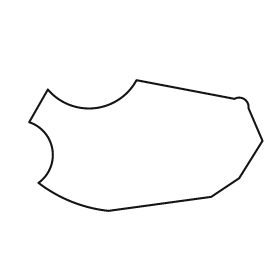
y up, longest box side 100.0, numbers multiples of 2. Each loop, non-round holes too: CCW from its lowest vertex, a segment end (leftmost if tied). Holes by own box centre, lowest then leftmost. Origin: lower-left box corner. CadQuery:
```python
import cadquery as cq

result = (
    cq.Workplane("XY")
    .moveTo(34.0, 0.0)
    .lineTo(78.0, 6.0)
    .lineTo(90.0, 14.0)
    .lineTo(100.0, 30.0)
    .lineTo(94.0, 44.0)
    .threePointArc((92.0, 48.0), (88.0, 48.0))
    .lineTo(46.0, 56.0)
    .threePointArc((28.0, 44.0), (8.0, 52.0))
    .lineTo(0.0, 38.0)
    .threePointArc((10.0, 26.0), (4.0, 12.0))
    .threePointArc((18.0, 4.0), (34.0, 0.0))
    .close()
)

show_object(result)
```